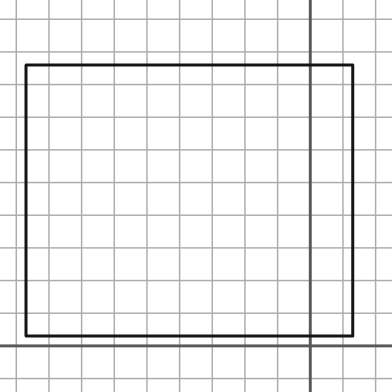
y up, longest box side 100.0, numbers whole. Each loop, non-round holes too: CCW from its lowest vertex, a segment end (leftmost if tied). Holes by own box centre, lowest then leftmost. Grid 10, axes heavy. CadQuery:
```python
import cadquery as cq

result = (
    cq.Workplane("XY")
    .moveTo(-87.0, 3.0)
    .lineTo(13.0, 3.0)
    .lineTo(13.0, 86.0)
    .lineTo(-87.0, 86.0)
    .close()
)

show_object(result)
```